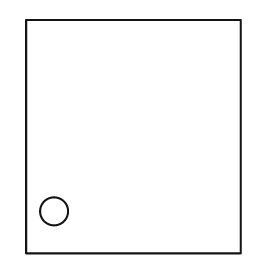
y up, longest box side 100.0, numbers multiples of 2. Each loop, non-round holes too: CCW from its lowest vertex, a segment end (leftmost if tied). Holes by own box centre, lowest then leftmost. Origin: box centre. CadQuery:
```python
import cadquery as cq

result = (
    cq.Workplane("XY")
    .moveTo(-46.0, -50.0)
    .lineTo(46.0, -50.0)
    .lineTo(46.0, 50.0)
    .lineTo(-46.0, 50.0)
    .close()
    .moveTo(-34.0, -32.0)
    .circle(6.0)
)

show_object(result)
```